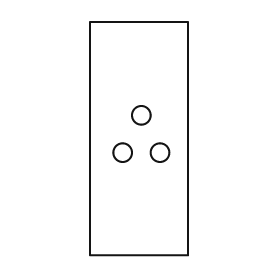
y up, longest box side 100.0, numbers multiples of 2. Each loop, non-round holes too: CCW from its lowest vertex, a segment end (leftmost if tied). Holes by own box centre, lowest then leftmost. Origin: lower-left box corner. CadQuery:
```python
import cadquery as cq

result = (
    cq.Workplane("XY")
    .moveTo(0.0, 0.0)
    .lineTo(42.0, 0.0)
    .lineTo(42.0, 100.0)
    .lineTo(0.0, 100.0)
    .close()
    .moveTo(14.0, 44.0)
    .circle(4.0)
    .moveTo(30.0, 44.0)
    .circle(4.0)
    .moveTo(22.0, 60.0)
    .circle(4.0)
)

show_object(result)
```